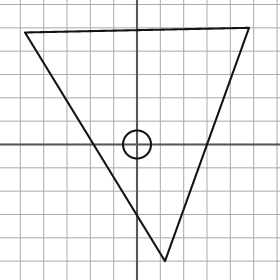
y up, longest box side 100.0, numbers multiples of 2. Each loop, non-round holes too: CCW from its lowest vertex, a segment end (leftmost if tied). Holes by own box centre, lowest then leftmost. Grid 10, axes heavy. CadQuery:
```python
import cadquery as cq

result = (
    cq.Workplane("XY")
    .moveTo(12.0, -50.0)
    .lineTo(48.0, 50.0)
    .lineTo(-48.0, 48.0)
    .close()
    .moveTo(0.0, 0.0)
    .circle(6.0)
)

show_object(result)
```